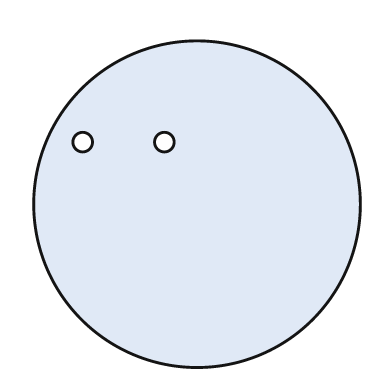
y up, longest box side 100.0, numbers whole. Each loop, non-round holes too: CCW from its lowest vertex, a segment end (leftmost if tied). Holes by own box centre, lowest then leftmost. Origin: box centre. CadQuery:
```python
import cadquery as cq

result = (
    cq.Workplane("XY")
    .moveTo(0.0, 0.0)
    .circle(50.0)
    .moveTo(-35.0, 19.0)
    .circle(3.0)
    .moveTo(-10.0, 19.0)
    .circle(3.0)
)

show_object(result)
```